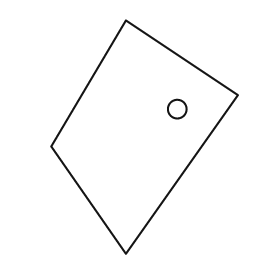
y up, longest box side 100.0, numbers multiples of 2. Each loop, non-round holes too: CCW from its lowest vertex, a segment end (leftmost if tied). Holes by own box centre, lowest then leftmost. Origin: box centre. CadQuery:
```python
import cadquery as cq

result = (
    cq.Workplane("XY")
    .moveTo(-8.0, -50.0)
    .lineTo(40.0, 18.0)
    .lineTo(-8.0, 50.0)
    .lineTo(-40.0, -4.0)
    .close()
    .moveTo(14.0, 12.0)
    .circle(4.0)
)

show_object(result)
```